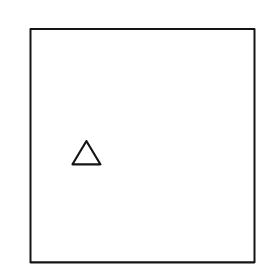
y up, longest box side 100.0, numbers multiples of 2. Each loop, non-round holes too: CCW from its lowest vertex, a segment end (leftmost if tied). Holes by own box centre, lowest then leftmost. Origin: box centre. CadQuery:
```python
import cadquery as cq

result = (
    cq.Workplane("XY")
    .moveTo(-48.0, -50.0)
    .lineTo(48.0, -50.0)
    .lineTo(48.0, 50.0)
    .lineTo(-48.0, 50.0)
    .close()
    .moveTo(-30.0, -8.0)
    .lineTo(-18.0, -8.0)
    .lineTo(-24.0, 2.0)
    .close()
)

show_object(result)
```